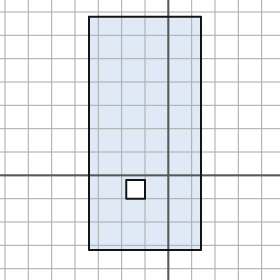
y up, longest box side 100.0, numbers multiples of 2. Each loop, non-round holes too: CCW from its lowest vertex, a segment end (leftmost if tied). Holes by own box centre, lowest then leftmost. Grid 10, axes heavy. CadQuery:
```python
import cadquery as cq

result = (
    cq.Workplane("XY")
    .moveTo(-34.0, -32.0)
    .lineTo(14.0, -32.0)
    .lineTo(14.0, 68.0)
    .lineTo(-34.0, 68.0)
    .close()
    .moveTo(-18.0, -10.0)
    .lineTo(-10.0, -10.0)
    .lineTo(-10.0, -2.0)
    .lineTo(-18.0, -2.0)
    .close()
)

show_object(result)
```